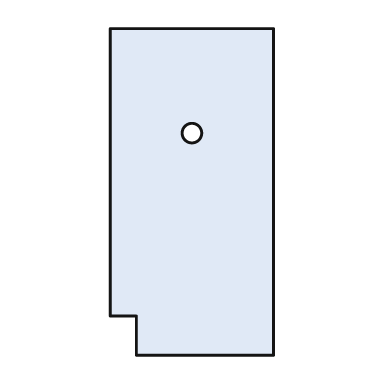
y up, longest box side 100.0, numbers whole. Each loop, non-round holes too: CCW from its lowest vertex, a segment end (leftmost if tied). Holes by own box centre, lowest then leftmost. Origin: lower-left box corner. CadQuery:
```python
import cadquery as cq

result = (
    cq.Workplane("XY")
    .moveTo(8.0, 0.0)
    .lineTo(50.0, 0.0)
    .lineTo(50.0, 100.0)
    .lineTo(0.0, 100.0)
    .lineTo(0.0, 12.0)
    .lineTo(8.0, 12.0)
    .close()
    .moveTo(25.0, 68.0)
    .circle(3.0)
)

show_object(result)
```